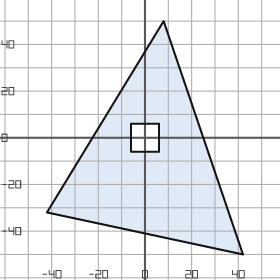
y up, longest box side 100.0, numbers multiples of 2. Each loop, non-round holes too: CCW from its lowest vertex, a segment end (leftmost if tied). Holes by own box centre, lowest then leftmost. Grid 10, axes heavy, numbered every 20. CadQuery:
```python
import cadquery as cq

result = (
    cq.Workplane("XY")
    .moveTo(42.0, -50.0)
    .lineTo(8.0, 50.0)
    .lineTo(-42.0, -32.0)
    .close()
    .moveTo(-6.0, -6.0)
    .lineTo(6.0, -6.0)
    .lineTo(6.0, 6.0)
    .lineTo(-6.0, 6.0)
    .close()
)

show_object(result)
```